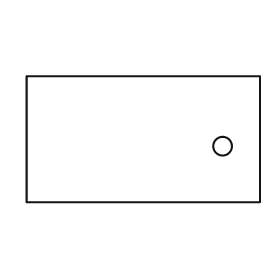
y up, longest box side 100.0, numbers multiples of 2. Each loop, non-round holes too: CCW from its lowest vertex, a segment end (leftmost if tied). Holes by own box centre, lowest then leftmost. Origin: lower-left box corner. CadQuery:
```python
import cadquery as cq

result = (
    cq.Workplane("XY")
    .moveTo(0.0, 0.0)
    .lineTo(100.0, 0.0)
    .lineTo(100.0, 54.0)
    .lineTo(0.0, 54.0)
    .close()
    .moveTo(84.0, 24.0)
    .circle(4.0)
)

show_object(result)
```